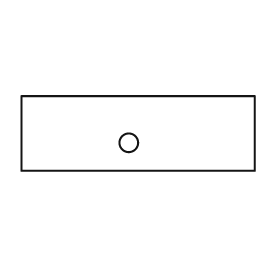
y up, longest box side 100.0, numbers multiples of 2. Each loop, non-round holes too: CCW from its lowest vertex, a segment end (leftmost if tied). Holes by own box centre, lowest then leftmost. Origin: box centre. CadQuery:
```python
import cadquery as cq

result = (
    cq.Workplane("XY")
    .moveTo(-50.0, -16.0)
    .lineTo(50.0, -16.0)
    .lineTo(50.0, 16.0)
    .lineTo(-50.0, 16.0)
    .close()
    .moveTo(-4.0, -4.0)
    .circle(4.0)
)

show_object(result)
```